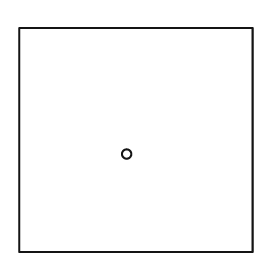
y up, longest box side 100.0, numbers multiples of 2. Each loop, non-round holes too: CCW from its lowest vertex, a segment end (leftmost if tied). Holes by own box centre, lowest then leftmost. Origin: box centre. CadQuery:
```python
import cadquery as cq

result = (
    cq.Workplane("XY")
    .moveTo(-50.0, -48.0)
    .lineTo(50.0, -48.0)
    .lineTo(50.0, 48.0)
    .lineTo(-50.0, 48.0)
    .close()
    .moveTo(-4.0, -6.0)
    .circle(2.0)
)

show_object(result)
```